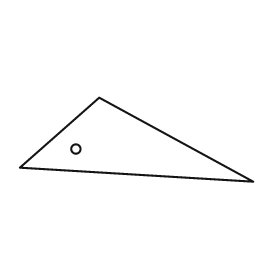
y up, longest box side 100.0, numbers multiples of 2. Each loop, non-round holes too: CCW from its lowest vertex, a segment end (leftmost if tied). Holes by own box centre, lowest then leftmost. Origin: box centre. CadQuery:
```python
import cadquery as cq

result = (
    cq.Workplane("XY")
    .moveTo(50.0, -18.0)
    .lineTo(-16.0, 18.0)
    .lineTo(-50.0, -12.0)
    .close()
    .moveTo(-26.0, -4.0)
    .circle(2.0)
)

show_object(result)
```